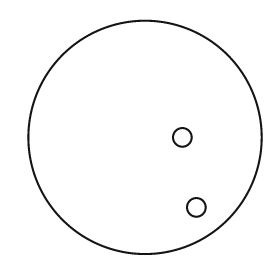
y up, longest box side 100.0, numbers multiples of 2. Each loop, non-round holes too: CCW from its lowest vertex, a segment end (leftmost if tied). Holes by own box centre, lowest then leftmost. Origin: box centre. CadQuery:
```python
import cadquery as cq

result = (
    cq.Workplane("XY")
    .moveTo(0.0, 0.0)
    .circle(50.0)
    .moveTo(22.0, -30.0)
    .circle(4.0)
    .moveTo(16.0, 0.0)
    .circle(4.0)
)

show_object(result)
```